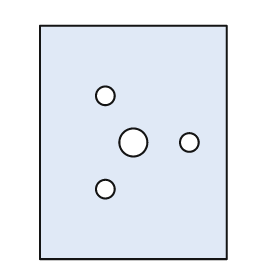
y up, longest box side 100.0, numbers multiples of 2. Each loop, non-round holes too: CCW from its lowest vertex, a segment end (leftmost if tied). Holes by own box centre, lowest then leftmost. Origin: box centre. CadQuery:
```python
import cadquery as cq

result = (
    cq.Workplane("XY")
    .moveTo(-40.0, -50.0)
    .lineTo(40.0, -50.0)
    .lineTo(40.0, 50.0)
    .lineTo(-40.0, 50.0)
    .close()
    .moveTo(-12.0, -20.0)
    .circle(4.0)
    .moveTo(0.0, 0.0)
    .circle(6.0)
    .moveTo(24.0, 0.0)
    .circle(4.0)
    .moveTo(-12.0, 20.0)
    .circle(4.0)
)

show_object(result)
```